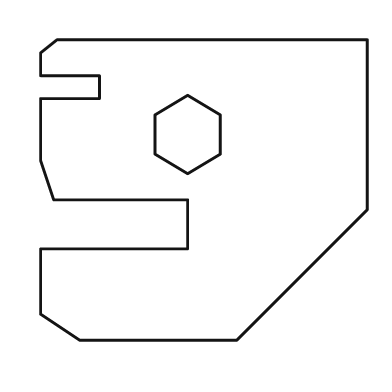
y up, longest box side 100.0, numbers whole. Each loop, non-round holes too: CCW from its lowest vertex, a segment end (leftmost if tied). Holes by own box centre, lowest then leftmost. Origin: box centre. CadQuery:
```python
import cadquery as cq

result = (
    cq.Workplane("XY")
    .moveTo(-38.0, -46.0)
    .lineTo(10.0, -46.0)
    .lineTo(50.0, -6.0)
    .lineTo(50.0, 46.0)
    .lineTo(-45.0, 46.0)
    .lineTo(-50.0, 42.0)
    .lineTo(-50.0, 35.0)
    .lineTo(-32.0, 35.0)
    .lineTo(-32.0, 28.0)
    .lineTo(-50.0, 28.0)
    .lineTo(-50.0, 9.0)
    .lineTo(-46.0, -3.0)
    .lineTo(-5.0, -3.0)
    .lineTo(-5.0, -18.0)
    .lineTo(-50.0, -18.0)
    .lineTo(-50.0, -38.0)
    .close()
    .moveTo(-5.0, 5.0)
    .lineTo(5.0, 11.0)
    .lineTo(5.0, 23.0)
    .lineTo(-5.0, 29.0)
    .lineTo(-15.0, 23.0)
    .lineTo(-15.0, 11.0)
    .close()
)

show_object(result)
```